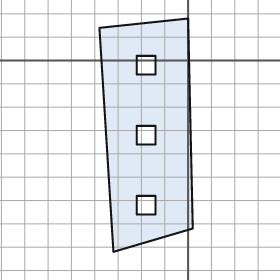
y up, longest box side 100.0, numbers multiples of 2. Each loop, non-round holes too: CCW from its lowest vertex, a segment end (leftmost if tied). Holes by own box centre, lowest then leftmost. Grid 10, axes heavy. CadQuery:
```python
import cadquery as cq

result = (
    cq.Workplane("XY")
    .moveTo(-32.0, -82.0)
    .lineTo(2.0, -72.0)
    .lineTo(0.0, 18.0)
    .lineTo(-38.0, 14.0)
    .close()
    .moveTo(-22.0, -66.0)
    .lineTo(-14.0, -66.0)
    .lineTo(-14.0, -58.0)
    .lineTo(-22.0, -58.0)
    .close()
    .moveTo(-22.0, -36.0)
    .lineTo(-14.0, -36.0)
    .lineTo(-14.0, -28.0)
    .lineTo(-22.0, -28.0)
    .close()
    .moveTo(-22.0, -6.0)
    .lineTo(-14.0, -6.0)
    .lineTo(-14.0, 2.0)
    .lineTo(-22.0, 2.0)
    .close()
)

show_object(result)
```